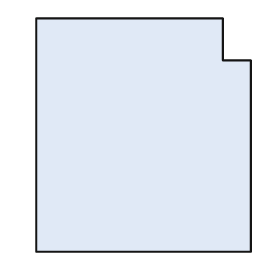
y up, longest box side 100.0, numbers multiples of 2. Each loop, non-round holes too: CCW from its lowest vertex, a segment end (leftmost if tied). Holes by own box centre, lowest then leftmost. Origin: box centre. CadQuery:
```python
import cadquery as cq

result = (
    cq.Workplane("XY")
    .moveTo(-46.0, -50.0)
    .lineTo(46.0, -50.0)
    .lineTo(46.0, 32.0)
    .lineTo(34.0, 32.0)
    .lineTo(34.0, 50.0)
    .lineTo(-46.0, 50.0)
    .close()
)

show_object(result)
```